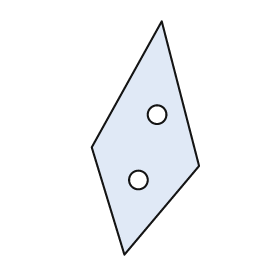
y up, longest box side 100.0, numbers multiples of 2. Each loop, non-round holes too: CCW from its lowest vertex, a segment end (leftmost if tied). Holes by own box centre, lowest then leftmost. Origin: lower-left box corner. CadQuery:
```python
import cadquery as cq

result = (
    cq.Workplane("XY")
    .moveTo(14.0, 0.0)
    .lineTo(46.0, 38.0)
    .lineTo(30.0, 100.0)
    .lineTo(0.0, 46.0)
    .close()
    .moveTo(20.0, 32.0)
    .circle(4.0)
    .moveTo(28.0, 60.0)
    .circle(4.0)
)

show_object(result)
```